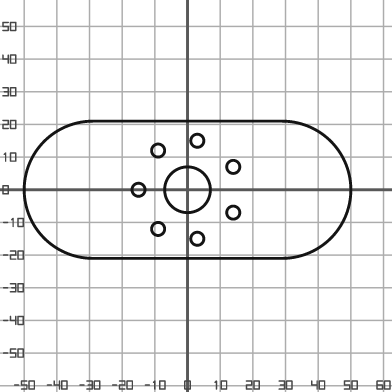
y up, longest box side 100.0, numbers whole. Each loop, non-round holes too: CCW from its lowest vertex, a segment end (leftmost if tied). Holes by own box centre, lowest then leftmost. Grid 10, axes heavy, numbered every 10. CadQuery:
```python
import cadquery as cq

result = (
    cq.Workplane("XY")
    .moveTo(-29.0, -21.0)
    .lineTo(29.0, -21.0)
    .threePointArc((50.0, 0.0), (29.0, 21.0))
    .lineTo(-29.0, 21.0)
    .threePointArc((-50.0, 0.0), (-29.0, -21.0))
    .close()
    .moveTo(3.0, -15.0)
    .circle(2.0)
    .moveTo(-9.0, -12.0)
    .circle(2.0)
    .moveTo(14.0, -7.0)
    .circle(2.0)
    .moveTo(-15.0, 0.0)
    .circle(2.0)
    .moveTo(0.0, 0.0)
    .circle(7.0)
    .moveTo(14.0, 7.0)
    .circle(2.0)
    .moveTo(-9.0, 12.0)
    .circle(2.0)
    .moveTo(3.0, 15.0)
    .circle(2.0)
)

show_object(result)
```